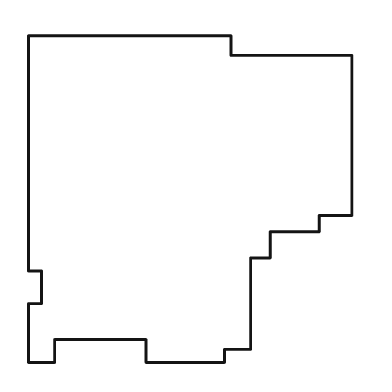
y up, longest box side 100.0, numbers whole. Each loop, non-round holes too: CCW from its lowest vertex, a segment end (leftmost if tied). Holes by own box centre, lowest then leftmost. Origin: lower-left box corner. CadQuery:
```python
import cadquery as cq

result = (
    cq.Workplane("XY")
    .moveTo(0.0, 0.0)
    .lineTo(8.0, 0.0)
    .lineTo(8.0, 7.0)
    .lineTo(36.0, 7.0)
    .lineTo(36.0, 0.0)
    .lineTo(60.0, 0.0)
    .lineTo(60.0, 4.0)
    .lineTo(68.0, 4.0)
    .lineTo(68.0, 32.0)
    .lineTo(74.0, 32.0)
    .lineTo(74.0, 40.0)
    .lineTo(89.0, 40.0)
    .lineTo(89.0, 45.0)
    .lineTo(99.0, 45.0)
    .lineTo(99.0, 94.0)
    .lineTo(62.0, 94.0)
    .lineTo(62.0, 100.0)
    .lineTo(0.0, 100.0)
    .lineTo(0.0, 28.0)
    .lineTo(4.0, 28.0)
    .lineTo(4.0, 18.0)
    .lineTo(0.0, 18.0)
    .close()
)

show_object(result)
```